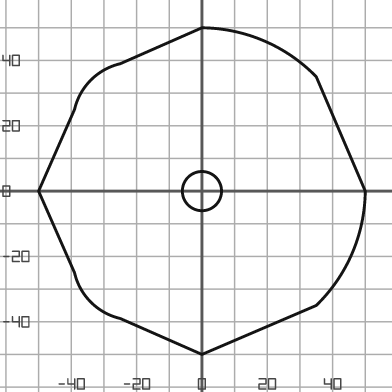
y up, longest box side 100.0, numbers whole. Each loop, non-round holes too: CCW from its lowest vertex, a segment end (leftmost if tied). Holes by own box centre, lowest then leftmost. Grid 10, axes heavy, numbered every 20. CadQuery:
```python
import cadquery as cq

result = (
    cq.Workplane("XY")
    .moveTo(0.0, -50.0)
    .lineTo(35.0, -35.0)
    .threePointArc((46.0, -19.0), (50.0, 0.0))
    .lineTo(35.0, 35.0)
    .threePointArc((19.0, 46.0), (0.0, 50.0))
    .lineTo(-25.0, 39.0)
    .threePointArc((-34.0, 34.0), (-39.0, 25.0))
    .lineTo(-50.0, 0.0)
    .lineTo(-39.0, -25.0)
    .threePointArc((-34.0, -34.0), (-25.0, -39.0))
    .close()
    .moveTo(0.0, 0.0)
    .circle(6.0)
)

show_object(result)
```